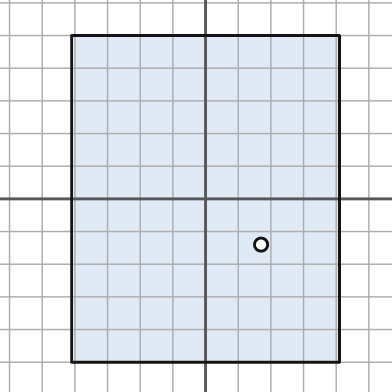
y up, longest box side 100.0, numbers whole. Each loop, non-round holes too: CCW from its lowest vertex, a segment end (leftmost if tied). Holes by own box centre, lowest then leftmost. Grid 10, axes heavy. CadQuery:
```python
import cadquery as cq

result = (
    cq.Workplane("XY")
    .moveTo(-41.0, -50.0)
    .lineTo(41.0, -50.0)
    .lineTo(41.0, 50.0)
    .lineTo(-41.0, 50.0)
    .close()
    .moveTo(17.0, -14.0)
    .circle(2.0)
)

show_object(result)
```